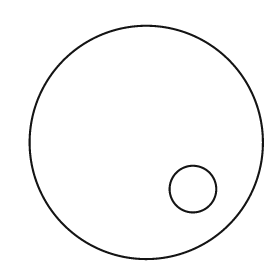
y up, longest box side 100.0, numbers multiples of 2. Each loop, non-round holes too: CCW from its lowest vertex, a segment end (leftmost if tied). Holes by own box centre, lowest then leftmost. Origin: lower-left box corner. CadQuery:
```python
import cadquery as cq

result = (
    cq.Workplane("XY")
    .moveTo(50.0, 50.0)
    .circle(50.0)
    .moveTo(70.0, 30.0)
    .circle(10.0)
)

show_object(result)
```